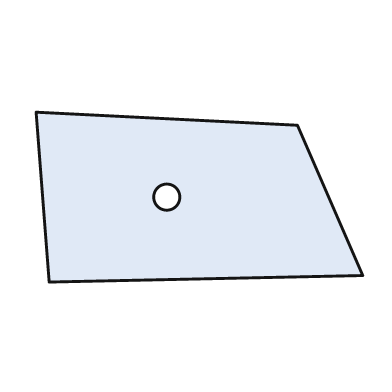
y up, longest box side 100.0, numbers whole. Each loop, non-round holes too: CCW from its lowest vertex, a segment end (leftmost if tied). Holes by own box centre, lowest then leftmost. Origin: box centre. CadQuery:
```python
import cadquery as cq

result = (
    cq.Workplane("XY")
    .moveTo(-46.0, -26.0)
    .lineTo(50.0, -24.0)
    .lineTo(30.0, 22.0)
    .lineTo(-50.0, 26.0)
    .close()
    .moveTo(-10.0, 0.0)
    .circle(4.0)
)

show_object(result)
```